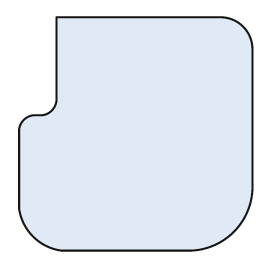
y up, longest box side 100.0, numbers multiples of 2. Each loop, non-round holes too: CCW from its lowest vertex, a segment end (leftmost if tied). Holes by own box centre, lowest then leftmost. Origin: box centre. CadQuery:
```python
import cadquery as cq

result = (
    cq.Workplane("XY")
    .moveTo(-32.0, -50.0)
    .lineTo(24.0, -50.0)
    .threePointArc((42.0, -42.0), (50.0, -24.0))
    .lineTo(50.0, 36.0)
    .threePointArc((46.0, 46.0), (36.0, 50.0))
    .lineTo(-34.0, 50.0)
    .lineTo(-34.0, 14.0)
    .threePointArc((-36.0, 10.0), (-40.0, 8.0))
    .lineTo(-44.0, 8.0)
    .threePointArc((-48.0, 6.0), (-50.0, 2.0))
    .lineTo(-50.0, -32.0)
    .threePointArc((-44.0, -44.0), (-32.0, -50.0))
    .close()
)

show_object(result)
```